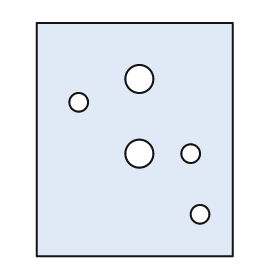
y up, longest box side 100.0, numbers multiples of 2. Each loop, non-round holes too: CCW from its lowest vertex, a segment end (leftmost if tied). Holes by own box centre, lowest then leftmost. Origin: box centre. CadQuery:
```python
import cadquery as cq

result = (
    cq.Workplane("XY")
    .moveTo(-42.0, -50.0)
    .lineTo(42.0, -50.0)
    .lineTo(42.0, 50.0)
    .lineTo(-42.0, 50.0)
    .close()
    .moveTo(28.0, -32.0)
    .circle(4.0)
    .moveTo(2.0, -6.0)
    .circle(6.0)
    .moveTo(24.0, -6.0)
    .circle(4.0)
    .moveTo(-24.0, 16.0)
    .circle(4.0)
    .moveTo(2.0, 26.0)
    .circle(6.0)
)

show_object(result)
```